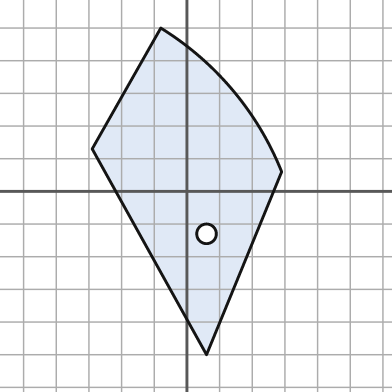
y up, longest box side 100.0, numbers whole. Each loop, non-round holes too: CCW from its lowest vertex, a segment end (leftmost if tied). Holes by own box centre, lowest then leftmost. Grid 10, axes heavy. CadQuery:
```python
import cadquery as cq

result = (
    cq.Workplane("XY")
    .moveTo(6.0, -50.0)
    .lineTo(29.0, 6.0)
    .threePointArc((14.0, 31.0), (-8.0, 50.0))
    .lineTo(-29.0, 13.0)
    .close()
    .moveTo(6.0, -13.0)
    .circle(3.0)
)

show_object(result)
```